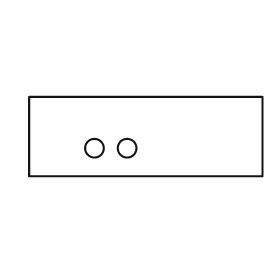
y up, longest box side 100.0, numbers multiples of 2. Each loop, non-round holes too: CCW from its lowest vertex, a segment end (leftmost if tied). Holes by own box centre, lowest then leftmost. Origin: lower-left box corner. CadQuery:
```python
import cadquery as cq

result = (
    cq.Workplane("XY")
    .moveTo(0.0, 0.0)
    .lineTo(100.0, 0.0)
    .lineTo(100.0, 34.0)
    .lineTo(0.0, 34.0)
    .close()
    .moveTo(28.0, 12.0)
    .circle(4.0)
    .moveTo(42.0, 12.0)
    .circle(4.0)
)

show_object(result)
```